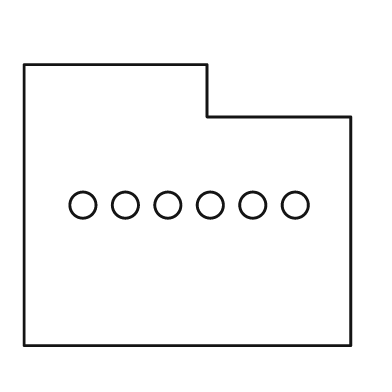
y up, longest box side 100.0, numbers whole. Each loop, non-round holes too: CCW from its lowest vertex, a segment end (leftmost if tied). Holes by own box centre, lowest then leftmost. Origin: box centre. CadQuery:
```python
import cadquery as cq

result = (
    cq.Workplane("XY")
    .moveTo(-50.0, -43.0)
    .lineTo(50.0, -43.0)
    .lineTo(50.0, 27.0)
    .lineTo(6.0, 27.0)
    .lineTo(6.0, 43.0)
    .lineTo(-50.0, 43.0)
    .close()
    .moveTo(-32.0, 0.0)
    .circle(4.0)
    .moveTo(-19.0, 0.0)
    .circle(4.0)
    .moveTo(-6.0, 0.0)
    .circle(4.0)
    .moveTo(7.0, 0.0)
    .circle(4.0)
    .moveTo(20.0, 0.0)
    .circle(4.0)
    .moveTo(33.0, 0.0)
    .circle(4.0)
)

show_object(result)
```